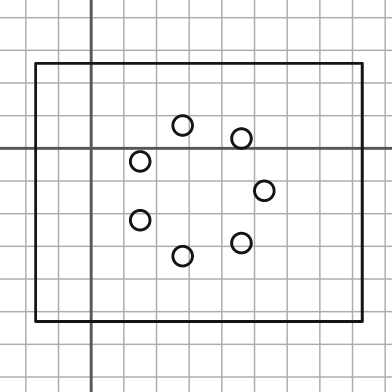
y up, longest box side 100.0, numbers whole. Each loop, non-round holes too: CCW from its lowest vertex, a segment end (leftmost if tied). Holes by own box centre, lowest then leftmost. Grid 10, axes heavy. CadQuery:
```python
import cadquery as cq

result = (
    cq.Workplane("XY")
    .moveTo(-17.0, -53.0)
    .lineTo(83.0, -53.0)
    .lineTo(83.0, 26.0)
    .lineTo(-17.0, 26.0)
    .close()
    .moveTo(28.0, -33.0)
    .circle(3.0)
    .moveTo(46.0, -29.0)
    .circle(3.0)
    .moveTo(15.0, -22.0)
    .circle(3.0)
    .moveTo(53.0, -13.0)
    .circle(3.0)
    .moveTo(15.0, -4.0)
    .circle(3.0)
    .moveTo(46.0, 3.0)
    .circle(3.0)
    .moveTo(28.0, 7.0)
    .circle(3.0)
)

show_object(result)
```